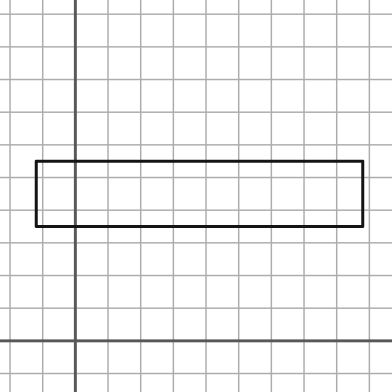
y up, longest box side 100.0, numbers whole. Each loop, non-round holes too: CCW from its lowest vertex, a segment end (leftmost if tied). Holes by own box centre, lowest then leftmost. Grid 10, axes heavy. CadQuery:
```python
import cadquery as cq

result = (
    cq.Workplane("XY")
    .moveTo(-12.0, 35.0)
    .lineTo(88.0, 35.0)
    .lineTo(88.0, 55.0)
    .lineTo(-12.0, 55.0)
    .close()
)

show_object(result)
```